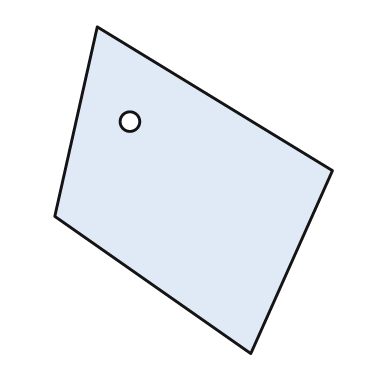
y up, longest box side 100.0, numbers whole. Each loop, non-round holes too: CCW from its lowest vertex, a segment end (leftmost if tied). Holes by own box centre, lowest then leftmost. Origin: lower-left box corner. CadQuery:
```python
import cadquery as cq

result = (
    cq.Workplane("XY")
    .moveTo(60.0, 0.0)
    .lineTo(85.0, 56.0)
    .lineTo(13.0, 100.0)
    .lineTo(0.0, 42.0)
    .close()
    .moveTo(23.0, 71.0)
    .circle(3.0)
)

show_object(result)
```